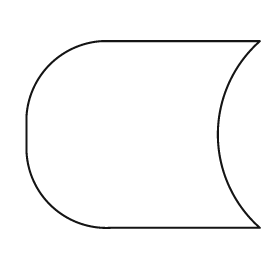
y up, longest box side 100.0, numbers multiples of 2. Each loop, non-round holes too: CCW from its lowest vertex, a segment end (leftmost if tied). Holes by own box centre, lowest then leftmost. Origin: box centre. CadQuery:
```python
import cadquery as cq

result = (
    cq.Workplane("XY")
    .moveTo(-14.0, -40.0)
    .lineTo(50.0, -40.0)
    .threePointArc((32.0, 0.0), (50.0, 40.0))
    .lineTo(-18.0, 40.0)
    .threePointArc((-40.0, 30.0), (-50.0, 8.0))
    .lineTo(-50.0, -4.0)
    .threePointArc((-40.0, -30.0), (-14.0, -40.0))
    .close()
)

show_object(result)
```